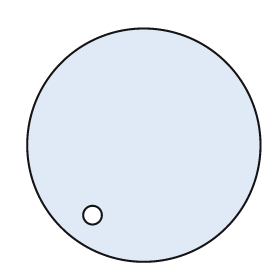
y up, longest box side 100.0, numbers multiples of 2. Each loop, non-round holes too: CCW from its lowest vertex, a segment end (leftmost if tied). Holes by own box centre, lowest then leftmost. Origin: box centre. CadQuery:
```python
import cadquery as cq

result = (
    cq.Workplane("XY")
    .moveTo(0.0, 0.0)
    .circle(50.0)
    .moveTo(-22.0, -30.0)
    .circle(4.0)
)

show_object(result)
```